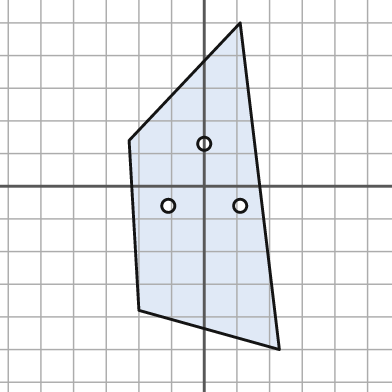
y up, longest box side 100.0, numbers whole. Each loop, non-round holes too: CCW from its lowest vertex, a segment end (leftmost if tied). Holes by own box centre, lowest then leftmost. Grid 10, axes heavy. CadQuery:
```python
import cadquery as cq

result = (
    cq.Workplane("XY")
    .moveTo(23.0, -50.0)
    .lineTo(11.0, 50.0)
    .lineTo(-23.0, 14.0)
    .lineTo(-20.0, -38.0)
    .close()
    .moveTo(-11.0, -6.0)
    .circle(2.0)
    .moveTo(11.0, -6.0)
    .circle(2.0)
    .moveTo(0.0, 13.0)
    .circle(2.0)
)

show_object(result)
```